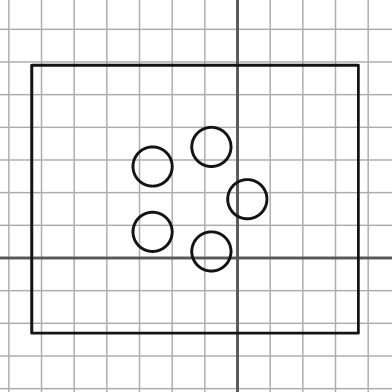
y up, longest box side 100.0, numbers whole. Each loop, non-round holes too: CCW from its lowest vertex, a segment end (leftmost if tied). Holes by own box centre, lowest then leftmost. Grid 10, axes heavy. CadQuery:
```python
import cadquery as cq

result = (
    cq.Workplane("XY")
    .moveTo(-63.0, -23.0)
    .lineTo(37.0, -23.0)
    .lineTo(37.0, 59.0)
    .lineTo(-63.0, 59.0)
    .close()
    .moveTo(-8.0, 2.0)
    .circle(6.0)
    .moveTo(-26.0, 8.0)
    .circle(6.0)
    .moveTo(3.0, 18.0)
    .circle(6.0)
    .moveTo(-26.0, 28.0)
    .circle(6.0)
    .moveTo(-8.0, 34.0)
    .circle(6.0)
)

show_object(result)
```